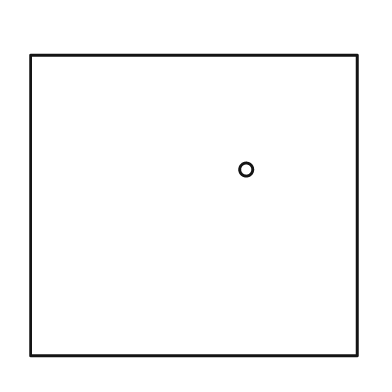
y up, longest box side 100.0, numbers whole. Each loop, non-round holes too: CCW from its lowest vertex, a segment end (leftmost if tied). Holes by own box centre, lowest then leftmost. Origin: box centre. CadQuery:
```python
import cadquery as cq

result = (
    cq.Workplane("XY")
    .moveTo(-50.0, -46.0)
    .lineTo(50.0, -46.0)
    .lineTo(50.0, 46.0)
    .lineTo(-50.0, 46.0)
    .close()
    .moveTo(16.0, 11.0)
    .circle(2.0)
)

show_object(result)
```